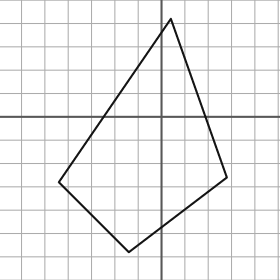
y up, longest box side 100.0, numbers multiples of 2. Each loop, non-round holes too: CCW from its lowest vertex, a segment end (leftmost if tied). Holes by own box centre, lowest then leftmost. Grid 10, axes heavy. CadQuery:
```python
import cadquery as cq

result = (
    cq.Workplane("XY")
    .moveTo(-14.0, -58.0)
    .lineTo(28.0, -26.0)
    .lineTo(4.0, 42.0)
    .lineTo(-44.0, -28.0)
    .close()
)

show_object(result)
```